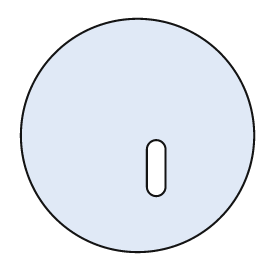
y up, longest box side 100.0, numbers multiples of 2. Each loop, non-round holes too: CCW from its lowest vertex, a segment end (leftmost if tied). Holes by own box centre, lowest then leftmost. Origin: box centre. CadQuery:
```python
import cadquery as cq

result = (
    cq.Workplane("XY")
    .moveTo(0.0, 0.0)
    .circle(50.0)
    .moveTo(4.0, -22.0)
    .threePointArc((8.0, -26.0), (12.0, -22.0))
    .lineTo(12.0, -6.0)
    .threePointArc((8.0, -2.0), (4.0, -6.0))
    .close()
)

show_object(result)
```